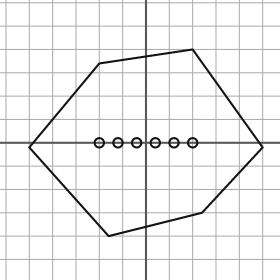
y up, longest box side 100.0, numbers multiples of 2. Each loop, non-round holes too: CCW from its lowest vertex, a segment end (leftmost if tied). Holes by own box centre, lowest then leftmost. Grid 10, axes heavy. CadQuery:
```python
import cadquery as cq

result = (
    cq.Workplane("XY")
    .moveTo(-16.0, -40.0)
    .lineTo(24.0, -30.0)
    .lineTo(50.0, -2.0)
    .lineTo(20.0, 40.0)
    .lineTo(-20.0, 34.0)
    .lineTo(-50.0, -2.0)
    .close()
    .moveTo(-20.0, 0.0)
    .circle(2.0)
    .moveTo(-12.0, 0.0)
    .circle(2.0)
    .moveTo(-4.0, 0.0)
    .circle(2.0)
    .moveTo(4.0, 0.0)
    .circle(2.0)
    .moveTo(12.0, 0.0)
    .circle(2.0)
    .moveTo(20.0, 0.0)
    .circle(2.0)
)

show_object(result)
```